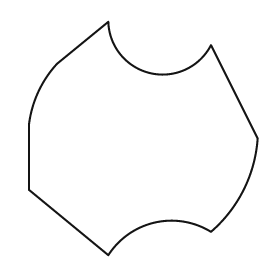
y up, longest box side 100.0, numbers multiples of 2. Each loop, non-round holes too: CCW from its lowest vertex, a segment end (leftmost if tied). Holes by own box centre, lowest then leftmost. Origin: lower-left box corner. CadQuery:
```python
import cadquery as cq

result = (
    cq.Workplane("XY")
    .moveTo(34.0, 0.0)
    .threePointArc((54.0, 14.0), (78.0, 10.0))
    .threePointArc((92.0, 28.0), (98.0, 50.0))
    .lineTo(78.0, 90.0)
    .threePointArc((52.0, 78.0), (34.0, 100.0))
    .lineTo(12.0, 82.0)
    .threePointArc((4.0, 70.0), (0.0, 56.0))
    .lineTo(0.0, 28.0)
    .close()
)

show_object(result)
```